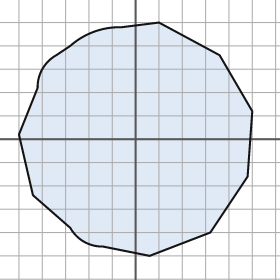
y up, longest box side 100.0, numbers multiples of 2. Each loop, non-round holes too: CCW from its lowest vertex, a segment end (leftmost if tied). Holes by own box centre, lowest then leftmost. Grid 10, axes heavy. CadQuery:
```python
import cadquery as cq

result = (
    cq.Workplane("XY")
    .moveTo(6.0, -50.0)
    .lineTo(32.0, -40.0)
    .lineTo(48.0, -16.0)
    .lineTo(50.0, 12.0)
    .lineTo(36.0, 36.0)
    .lineTo(10.0, 50.0)
    .lineTo(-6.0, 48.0)
    .threePointArc((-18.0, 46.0), (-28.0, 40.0))
    .lineTo(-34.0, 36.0)
    .threePointArc((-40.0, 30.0), (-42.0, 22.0))
    .lineTo(-50.0, 2.0)
    .lineTo(-44.0, -24.0)
    .lineTo(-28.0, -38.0)
    .threePointArc((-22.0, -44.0), (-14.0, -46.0))
    .close()
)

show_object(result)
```